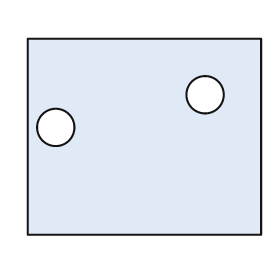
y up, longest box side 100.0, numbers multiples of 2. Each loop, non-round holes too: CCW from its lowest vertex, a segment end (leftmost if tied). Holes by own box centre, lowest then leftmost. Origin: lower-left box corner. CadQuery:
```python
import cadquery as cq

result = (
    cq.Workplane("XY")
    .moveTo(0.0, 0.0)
    .lineTo(100.0, 0.0)
    .lineTo(100.0, 84.0)
    .lineTo(0.0, 84.0)
    .close()
    .moveTo(12.0, 46.0)
    .circle(8.0)
    .moveTo(76.0, 60.0)
    .circle(8.0)
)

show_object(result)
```